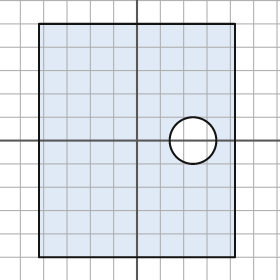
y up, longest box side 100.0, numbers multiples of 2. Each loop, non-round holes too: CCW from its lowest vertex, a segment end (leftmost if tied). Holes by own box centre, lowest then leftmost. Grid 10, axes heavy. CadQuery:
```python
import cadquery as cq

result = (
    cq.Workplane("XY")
    .moveTo(-42.0, -50.0)
    .lineTo(42.0, -50.0)
    .lineTo(42.0, 50.0)
    .lineTo(-42.0, 50.0)
    .close()
    .moveTo(24.0, 0.0)
    .circle(10.0)
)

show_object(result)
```